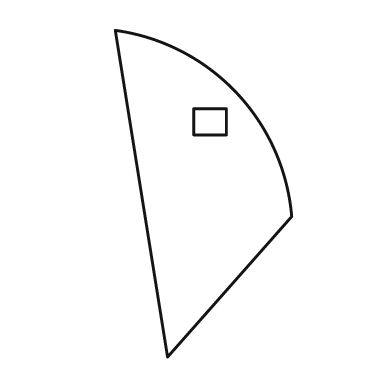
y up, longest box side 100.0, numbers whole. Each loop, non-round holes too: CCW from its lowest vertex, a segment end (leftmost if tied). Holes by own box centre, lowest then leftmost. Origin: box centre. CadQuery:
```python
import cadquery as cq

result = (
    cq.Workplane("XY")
    .moveTo(-11.0, -50.0)
    .lineTo(27.0, -7.0)
    .threePointArc((10.0, 31.0), (-27.0, 50.0))
    .close()
    .moveTo(-3.0, 18.0)
    .lineTo(7.0, 18.0)
    .lineTo(7.0, 26.0)
    .lineTo(-3.0, 26.0)
    .close()
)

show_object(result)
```